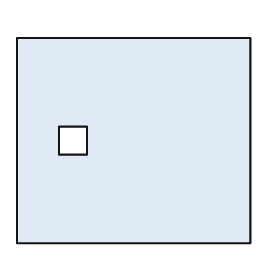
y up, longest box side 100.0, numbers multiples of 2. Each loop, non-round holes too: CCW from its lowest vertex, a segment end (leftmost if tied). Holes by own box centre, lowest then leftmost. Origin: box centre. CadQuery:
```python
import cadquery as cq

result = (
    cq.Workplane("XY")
    .moveTo(-50.0, -44.0)
    .lineTo(50.0, -44.0)
    .lineTo(50.0, 44.0)
    .lineTo(-50.0, 44.0)
    .close()
    .moveTo(-32.0, -6.0)
    .lineTo(-20.0, -6.0)
    .lineTo(-20.0, 6.0)
    .lineTo(-32.0, 6.0)
    .close()
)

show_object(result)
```